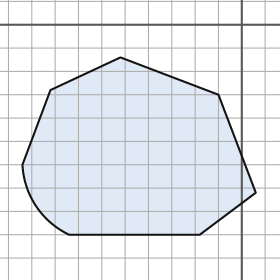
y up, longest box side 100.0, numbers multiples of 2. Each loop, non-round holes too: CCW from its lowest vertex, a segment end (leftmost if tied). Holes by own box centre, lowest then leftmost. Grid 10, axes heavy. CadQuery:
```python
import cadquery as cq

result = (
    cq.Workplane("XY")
    .moveTo(-74.0, -90.0)
    .lineTo(-18.0, -90.0)
    .lineTo(6.0, -72.0)
    .lineTo(-10.0, -30.0)
    .lineTo(-52.0, -14.0)
    .lineTo(-82.0, -28.0)
    .lineTo(-94.0, -60.0)
    .threePointArc((-88.0, -78.0), (-74.0, -90.0))
    .close()
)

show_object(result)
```